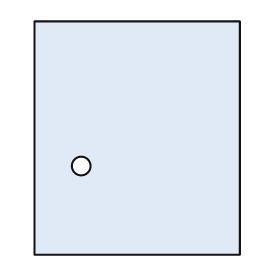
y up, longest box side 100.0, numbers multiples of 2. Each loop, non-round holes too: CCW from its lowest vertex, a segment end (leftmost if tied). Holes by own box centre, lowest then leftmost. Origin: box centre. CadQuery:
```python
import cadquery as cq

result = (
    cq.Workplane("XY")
    .moveTo(-44.0, -50.0)
    .lineTo(44.0, -50.0)
    .lineTo(44.0, 50.0)
    .lineTo(-44.0, 50.0)
    .close()
    .moveTo(-24.0, -12.0)
    .circle(4.0)
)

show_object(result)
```